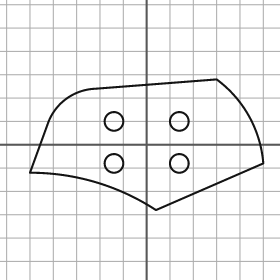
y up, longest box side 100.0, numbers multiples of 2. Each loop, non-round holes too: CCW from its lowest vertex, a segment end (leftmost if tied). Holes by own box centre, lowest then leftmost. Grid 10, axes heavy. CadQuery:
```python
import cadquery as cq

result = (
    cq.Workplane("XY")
    .moveTo(4.0, -28.0)
    .lineTo(50.0, -8.0)
    .threePointArc((44.0, 12.0), (30.0, 28.0))
    .lineTo(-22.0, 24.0)
    .threePointArc((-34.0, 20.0), (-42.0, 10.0))
    .lineTo(-50.0, -12.0)
    .threePointArc((-22.0, -16.0), (4.0, -28.0))
    .close()
    .moveTo(-14.0, -8.0)
    .circle(4.0)
    .moveTo(14.0, -8.0)
    .circle(4.0)
    .moveTo(-14.0, 10.0)
    .circle(4.0)
    .moveTo(14.0, 10.0)
    .circle(4.0)
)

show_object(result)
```